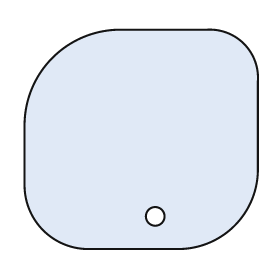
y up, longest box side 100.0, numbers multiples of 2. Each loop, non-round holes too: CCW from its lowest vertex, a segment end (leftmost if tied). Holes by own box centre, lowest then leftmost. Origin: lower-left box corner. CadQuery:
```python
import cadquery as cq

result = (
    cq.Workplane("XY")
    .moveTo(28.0, 0.0)
    .lineTo(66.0, 0.0)
    .threePointArc((90.0, 10.0), (100.0, 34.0))
    .lineTo(100.0, 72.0)
    .threePointArc((94.0, 88.0), (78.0, 94.0))
    .lineTo(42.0, 94.0)
    .threePointArc((12.0, 82.0), (0.0, 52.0))
    .lineTo(0.0, 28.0)
    .threePointArc((8.0, 8.0), (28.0, 0.0))
    .close()
    .moveTo(56.0, 14.0)
    .circle(4.0)
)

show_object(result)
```